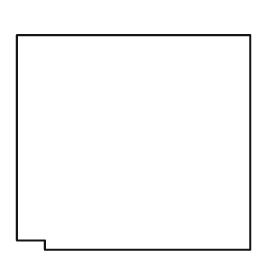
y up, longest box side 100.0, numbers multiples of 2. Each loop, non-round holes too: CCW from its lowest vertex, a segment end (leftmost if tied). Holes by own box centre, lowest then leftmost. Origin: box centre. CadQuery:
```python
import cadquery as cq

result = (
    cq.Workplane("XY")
    .moveTo(-38.0, -46.0)
    .lineTo(50.0, -46.0)
    .lineTo(50.0, 46.0)
    .lineTo(-50.0, 46.0)
    .lineTo(-50.0, -42.0)
    .lineTo(-38.0, -42.0)
    .close()
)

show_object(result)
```